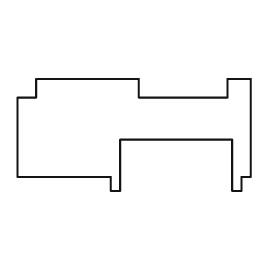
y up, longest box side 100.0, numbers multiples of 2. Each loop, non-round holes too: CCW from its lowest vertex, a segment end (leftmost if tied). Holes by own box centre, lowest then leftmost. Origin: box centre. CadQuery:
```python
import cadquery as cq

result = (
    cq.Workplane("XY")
    .moveTo(-10.0, -24.0)
    .lineTo(-6.0, -24.0)
    .lineTo(-6.0, -2.0)
    .lineTo(42.0, -2.0)
    .lineTo(42.0, -24.0)
    .lineTo(46.0, -24.0)
    .lineTo(46.0, -18.0)
    .lineTo(50.0, -18.0)
    .lineTo(50.0, 24.0)
    .lineTo(40.0, 24.0)
    .lineTo(40.0, 16.0)
    .lineTo(2.0, 16.0)
    .lineTo(2.0, 24.0)
    .lineTo(-42.0, 24.0)
    .lineTo(-42.0, 16.0)
    .lineTo(-50.0, 16.0)
    .lineTo(-50.0, -18.0)
    .lineTo(-10.0, -18.0)
    .close()
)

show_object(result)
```